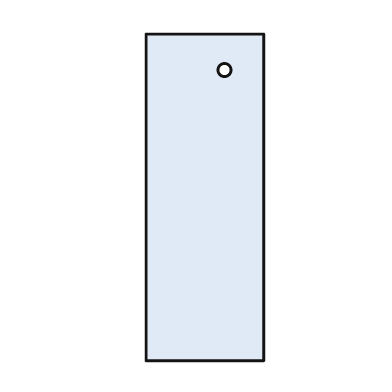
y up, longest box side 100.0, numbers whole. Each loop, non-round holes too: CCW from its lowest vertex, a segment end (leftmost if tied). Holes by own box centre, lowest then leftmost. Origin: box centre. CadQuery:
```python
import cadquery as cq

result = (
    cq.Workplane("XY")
    .moveTo(-18.0, -50.0)
    .lineTo(18.0, -50.0)
    .lineTo(18.0, 50.0)
    .lineTo(-18.0, 50.0)
    .close()
    .moveTo(6.0, 39.0)
    .circle(2.0)
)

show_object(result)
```